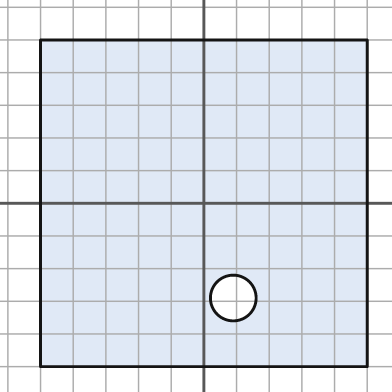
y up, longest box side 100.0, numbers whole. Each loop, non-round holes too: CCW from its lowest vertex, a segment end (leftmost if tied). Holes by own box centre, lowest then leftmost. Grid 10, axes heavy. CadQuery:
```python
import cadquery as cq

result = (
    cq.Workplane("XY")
    .moveTo(-50.0, -50.0)
    .lineTo(50.0, -50.0)
    .lineTo(50.0, 50.0)
    .lineTo(-50.0, 50.0)
    .close()
    .moveTo(9.0, -29.0)
    .circle(7.0)
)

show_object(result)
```